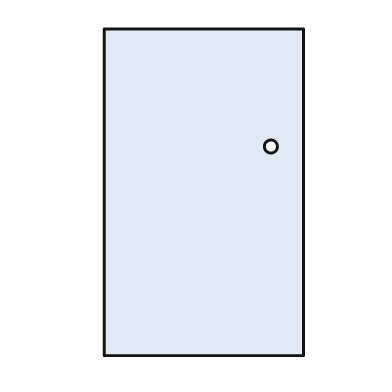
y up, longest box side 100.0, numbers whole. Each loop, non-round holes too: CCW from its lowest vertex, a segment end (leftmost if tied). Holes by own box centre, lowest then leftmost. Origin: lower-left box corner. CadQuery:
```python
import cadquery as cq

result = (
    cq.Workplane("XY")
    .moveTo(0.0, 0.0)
    .lineTo(61.0, 0.0)
    .lineTo(61.0, 100.0)
    .lineTo(0.0, 100.0)
    .close()
    .moveTo(51.0, 64.0)
    .circle(2.0)
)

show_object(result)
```